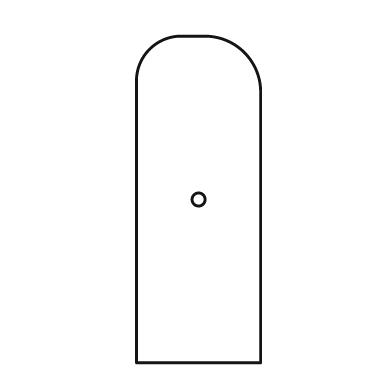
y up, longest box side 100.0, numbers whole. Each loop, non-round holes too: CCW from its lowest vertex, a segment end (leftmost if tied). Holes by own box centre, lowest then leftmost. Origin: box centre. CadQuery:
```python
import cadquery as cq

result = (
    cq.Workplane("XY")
    .moveTo(-19.0, -50.0)
    .lineTo(19.0, -50.0)
    .lineTo(19.0, 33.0)
    .threePointArc((14.0, 45.0), (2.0, 50.0))
    .lineTo(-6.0, 50.0)
    .threePointArc((-15.0, 46.0), (-19.0, 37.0))
    .close()
    .moveTo(0.0, 0.0)
    .circle(2.0)
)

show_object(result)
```